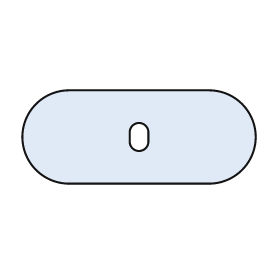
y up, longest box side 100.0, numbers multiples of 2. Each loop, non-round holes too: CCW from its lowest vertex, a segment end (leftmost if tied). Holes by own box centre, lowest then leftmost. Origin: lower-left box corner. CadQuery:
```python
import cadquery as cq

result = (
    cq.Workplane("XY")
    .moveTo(20.0, 0.0)
    .lineTo(80.0, 0.0)
    .threePointArc((100.0, 20.0), (80.0, 40.0))
    .lineTo(20.0, 40.0)
    .threePointArc((0.0, 20.0), (20.0, 0.0))
    .close()
    .moveTo(46.0, 18.0)
    .threePointArc((50.0, 14.0), (54.0, 18.0))
    .lineTo(54.0, 22.0)
    .threePointArc((50.0, 26.0), (46.0, 22.0))
    .close()
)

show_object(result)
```